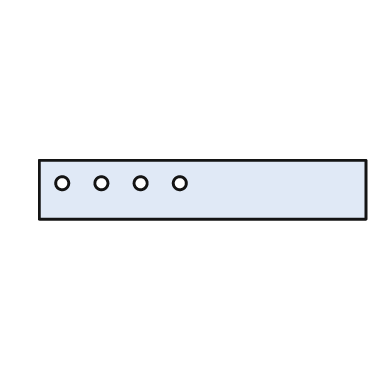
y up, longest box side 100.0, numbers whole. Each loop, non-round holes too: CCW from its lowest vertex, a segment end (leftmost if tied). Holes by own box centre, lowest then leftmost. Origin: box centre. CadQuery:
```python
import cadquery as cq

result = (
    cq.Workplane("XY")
    .moveTo(-50.0, -9.0)
    .lineTo(50.0, -9.0)
    .lineTo(50.0, 9.0)
    .lineTo(-50.0, 9.0)
    .close()
    .moveTo(-43.0, 2.0)
    .circle(2.0)
    .moveTo(-31.0, 2.0)
    .circle(2.0)
    .moveTo(-19.0, 2.0)
    .circle(2.0)
    .moveTo(-7.0, 2.0)
    .circle(2.0)
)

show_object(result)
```